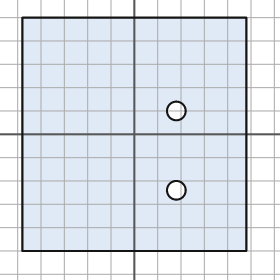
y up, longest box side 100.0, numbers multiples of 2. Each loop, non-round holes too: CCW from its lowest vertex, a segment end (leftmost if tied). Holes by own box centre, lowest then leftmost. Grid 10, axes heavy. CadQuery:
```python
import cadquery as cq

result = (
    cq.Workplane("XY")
    .moveTo(-48.0, -50.0)
    .lineTo(48.0, -50.0)
    .lineTo(48.0, 50.0)
    .lineTo(-48.0, 50.0)
    .close()
    .moveTo(18.0, -24.0)
    .circle(4.0)
    .moveTo(18.0, 10.0)
    .circle(4.0)
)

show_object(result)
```